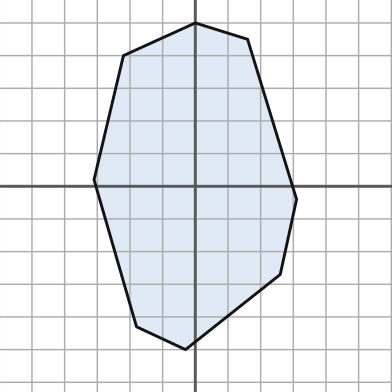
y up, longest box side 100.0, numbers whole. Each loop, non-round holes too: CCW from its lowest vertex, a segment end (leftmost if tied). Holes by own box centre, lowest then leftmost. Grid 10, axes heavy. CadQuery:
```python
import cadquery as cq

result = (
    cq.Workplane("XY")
    .moveTo(-3.0, -50.0)
    .lineTo(26.0, -27.0)
    .lineTo(31.0, -4.0)
    .lineTo(16.0, 45.0)
    .lineTo(0.0, 50.0)
    .lineTo(-22.0, 40.0)
    .lineTo(-31.0, 2.0)
    .lineTo(-18.0, -43.0)
    .close()
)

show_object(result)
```